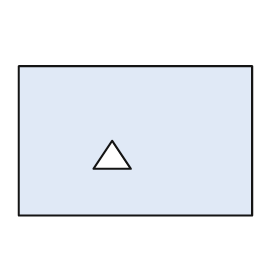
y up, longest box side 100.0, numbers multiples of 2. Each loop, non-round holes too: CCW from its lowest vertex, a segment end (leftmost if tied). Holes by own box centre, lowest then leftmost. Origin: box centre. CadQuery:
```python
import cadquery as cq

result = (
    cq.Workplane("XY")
    .moveTo(-50.0, -32.0)
    .lineTo(50.0, -32.0)
    .lineTo(50.0, 32.0)
    .lineTo(-50.0, 32.0)
    .close()
    .moveTo(-18.0, -12.0)
    .lineTo(-2.0, -12.0)
    .lineTo(-10.0, 0.0)
    .close()
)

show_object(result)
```